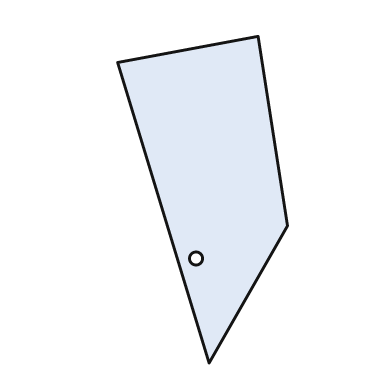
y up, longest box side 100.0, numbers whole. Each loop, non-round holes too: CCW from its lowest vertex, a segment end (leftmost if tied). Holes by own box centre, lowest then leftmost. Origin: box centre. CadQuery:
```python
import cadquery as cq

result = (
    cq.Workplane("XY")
    .moveTo(2.0, -50.0)
    .lineTo(26.0, -8.0)
    .lineTo(17.0, 50.0)
    .lineTo(-26.0, 42.0)
    .close()
    .moveTo(-2.0, -18.0)
    .circle(2.0)
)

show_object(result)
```